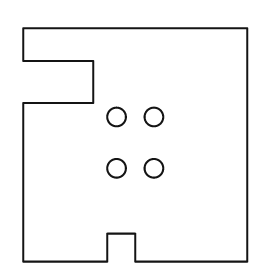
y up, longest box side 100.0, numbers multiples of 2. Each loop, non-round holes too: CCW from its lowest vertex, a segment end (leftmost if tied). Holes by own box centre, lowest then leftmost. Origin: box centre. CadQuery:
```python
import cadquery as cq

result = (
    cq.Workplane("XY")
    .moveTo(-48.0, -50.0)
    .lineTo(-12.0, -50.0)
    .lineTo(-12.0, -38.0)
    .lineTo(0.0, -38.0)
    .lineTo(0.0, -50.0)
    .lineTo(48.0, -50.0)
    .lineTo(48.0, 50.0)
    .lineTo(-48.0, 50.0)
    .lineTo(-48.0, 36.0)
    .lineTo(-18.0, 36.0)
    .lineTo(-18.0, 18.0)
    .lineTo(-48.0, 18.0)
    .close()
    .moveTo(-8.0, -10.0)
    .circle(4.0)
    .moveTo(8.0, -10.0)
    .circle(4.0)
    .moveTo(-8.0, 12.0)
    .circle(4.0)
    .moveTo(8.0, 12.0)
    .circle(4.0)
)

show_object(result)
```